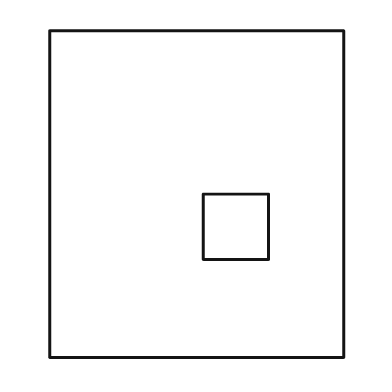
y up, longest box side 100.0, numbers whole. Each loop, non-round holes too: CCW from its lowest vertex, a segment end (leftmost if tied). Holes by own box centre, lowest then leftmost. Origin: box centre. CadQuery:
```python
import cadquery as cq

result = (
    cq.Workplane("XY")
    .moveTo(-45.0, -50.0)
    .lineTo(45.0, -50.0)
    .lineTo(45.0, 50.0)
    .lineTo(-45.0, 50.0)
    .close()
    .moveTo(2.0, -20.0)
    .lineTo(22.0, -20.0)
    .lineTo(22.0, 0.0)
    .lineTo(2.0, 0.0)
    .close()
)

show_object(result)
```